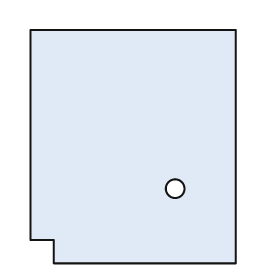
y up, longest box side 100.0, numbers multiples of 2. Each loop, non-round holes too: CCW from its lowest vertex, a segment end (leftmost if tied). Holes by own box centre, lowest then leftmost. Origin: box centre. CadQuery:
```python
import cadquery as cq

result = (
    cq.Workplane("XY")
    .moveTo(-34.0, -50.0)
    .lineTo(44.0, -50.0)
    .lineTo(44.0, 50.0)
    .lineTo(-44.0, 50.0)
    .lineTo(-44.0, -40.0)
    .lineTo(-34.0, -40.0)
    .close()
    .moveTo(18.0, -18.0)
    .circle(4.0)
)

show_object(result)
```